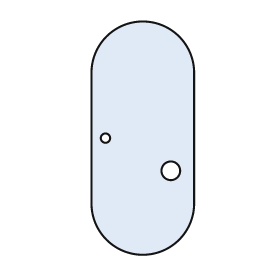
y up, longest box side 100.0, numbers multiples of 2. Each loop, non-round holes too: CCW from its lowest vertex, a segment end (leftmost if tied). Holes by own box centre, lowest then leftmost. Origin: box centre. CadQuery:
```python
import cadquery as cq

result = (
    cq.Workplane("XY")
    .moveTo(-22.0, -28.0)
    .threePointArc((0.0, -50.0), (22.0, -28.0))
    .lineTo(22.0, 28.0)
    .threePointArc((0.0, 50.0), (-22.0, 28.0))
    .close()
    .moveTo(12.0, -14.0)
    .circle(4.0)
    .moveTo(-16.0, 0.0)
    .circle(2.0)
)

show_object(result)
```